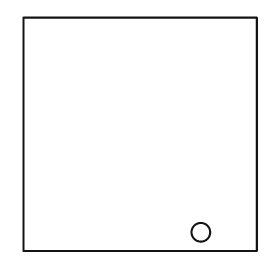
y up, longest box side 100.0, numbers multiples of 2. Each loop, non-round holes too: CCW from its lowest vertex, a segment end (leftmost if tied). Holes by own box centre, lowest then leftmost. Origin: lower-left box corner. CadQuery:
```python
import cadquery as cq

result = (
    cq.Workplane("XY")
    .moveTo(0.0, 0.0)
    .lineTo(100.0, 0.0)
    .lineTo(100.0, 100.0)
    .lineTo(0.0, 100.0)
    .close()
    .moveTo(76.0, 8.0)
    .circle(4.0)
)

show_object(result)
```